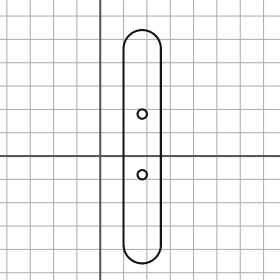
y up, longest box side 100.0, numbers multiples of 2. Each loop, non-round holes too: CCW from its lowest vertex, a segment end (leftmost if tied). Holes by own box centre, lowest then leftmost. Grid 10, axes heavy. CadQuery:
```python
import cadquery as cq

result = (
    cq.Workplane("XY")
    .moveTo(10.0, -38.0)
    .threePointArc((18.0, -46.0), (26.0, -38.0))
    .lineTo(26.0, 46.0)
    .threePointArc((18.0, 54.0), (10.0, 46.0))
    .close()
    .moveTo(18.0, -8.0)
    .circle(2.0)
    .moveTo(18.0, 18.0)
    .circle(2.0)
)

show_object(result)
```